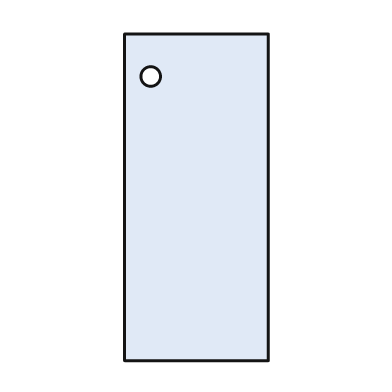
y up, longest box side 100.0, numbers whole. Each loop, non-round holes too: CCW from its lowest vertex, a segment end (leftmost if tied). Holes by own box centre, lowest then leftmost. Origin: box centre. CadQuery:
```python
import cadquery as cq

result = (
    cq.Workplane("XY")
    .moveTo(-22.0, -50.0)
    .lineTo(22.0, -50.0)
    .lineTo(22.0, 50.0)
    .lineTo(-22.0, 50.0)
    .close()
    .moveTo(-14.0, 37.0)
    .circle(3.0)
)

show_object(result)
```